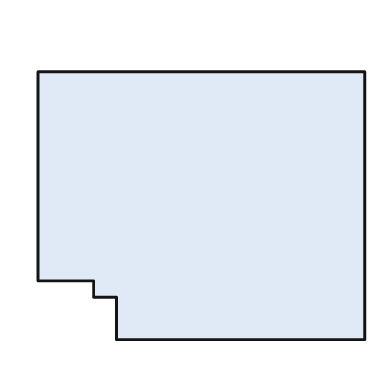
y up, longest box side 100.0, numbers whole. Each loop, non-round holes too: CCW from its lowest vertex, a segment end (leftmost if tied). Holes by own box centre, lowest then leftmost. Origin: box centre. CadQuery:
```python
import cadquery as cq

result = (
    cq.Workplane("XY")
    .moveTo(-26.0, -41.0)
    .lineTo(50.0, -41.0)
    .lineTo(50.0, 41.0)
    .lineTo(-50.0, 41.0)
    .lineTo(-50.0, -23.0)
    .lineTo(-33.0, -23.0)
    .lineTo(-33.0, -28.0)
    .lineTo(-26.0, -28.0)
    .close()
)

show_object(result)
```